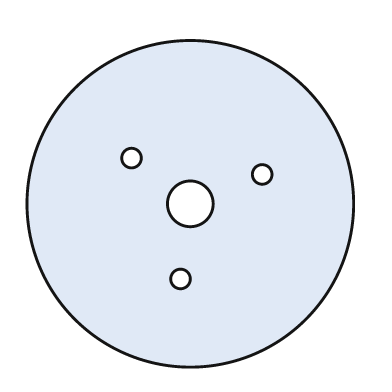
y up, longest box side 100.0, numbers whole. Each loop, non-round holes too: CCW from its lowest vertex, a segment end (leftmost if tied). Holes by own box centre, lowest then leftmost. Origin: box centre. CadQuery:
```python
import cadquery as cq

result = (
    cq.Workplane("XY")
    .moveTo(0.0, 0.0)
    .circle(50.0)
    .moveTo(-3.0, -23.0)
    .circle(3.0)
    .moveTo(0.0, 0.0)
    .circle(7.0)
    .moveTo(22.0, 9.0)
    .circle(3.0)
    .moveTo(-18.0, 14.0)
    .circle(3.0)
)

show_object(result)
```